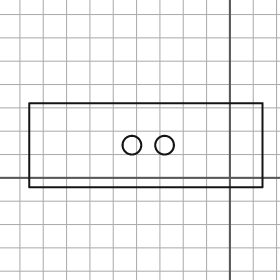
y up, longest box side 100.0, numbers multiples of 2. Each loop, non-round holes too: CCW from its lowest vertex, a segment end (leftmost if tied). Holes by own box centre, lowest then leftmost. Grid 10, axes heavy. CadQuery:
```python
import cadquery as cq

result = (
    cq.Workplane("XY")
    .moveTo(-86.0, -4.0)
    .lineTo(14.0, -4.0)
    .lineTo(14.0, 32.0)
    .lineTo(-86.0, 32.0)
    .close()
    .moveTo(-42.0, 14.0)
    .circle(4.0)
    .moveTo(-28.0, 14.0)
    .circle(4.0)
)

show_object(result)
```